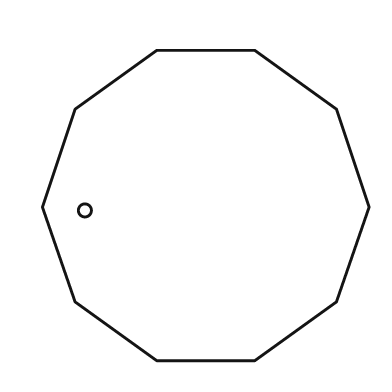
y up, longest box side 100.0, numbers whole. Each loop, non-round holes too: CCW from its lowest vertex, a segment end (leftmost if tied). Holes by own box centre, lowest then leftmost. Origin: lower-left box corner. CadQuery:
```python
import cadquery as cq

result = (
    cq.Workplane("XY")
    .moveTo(35.0, 0.0)
    .lineTo(65.0, 0.0)
    .lineTo(90.0, 18.0)
    .lineTo(100.0, 47.0)
    .lineTo(90.0, 77.0)
    .lineTo(65.0, 95.0)
    .lineTo(35.0, 95.0)
    .lineTo(10.0, 77.0)
    .lineTo(0.0, 47.0)
    .lineTo(10.0, 18.0)
    .close()
    .moveTo(13.0, 46.0)
    .circle(2.0)
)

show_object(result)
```